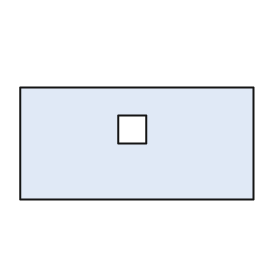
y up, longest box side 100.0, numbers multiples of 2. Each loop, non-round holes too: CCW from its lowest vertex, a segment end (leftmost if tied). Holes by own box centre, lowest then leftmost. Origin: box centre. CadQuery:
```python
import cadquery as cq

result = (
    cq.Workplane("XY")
    .moveTo(-50.0, -24.0)
    .lineTo(50.0, -24.0)
    .lineTo(50.0, 24.0)
    .lineTo(-50.0, 24.0)
    .close()
    .moveTo(-8.0, 0.0)
    .lineTo(4.0, 0.0)
    .lineTo(4.0, 12.0)
    .lineTo(-8.0, 12.0)
    .close()
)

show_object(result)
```